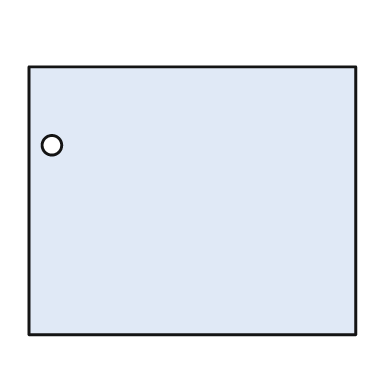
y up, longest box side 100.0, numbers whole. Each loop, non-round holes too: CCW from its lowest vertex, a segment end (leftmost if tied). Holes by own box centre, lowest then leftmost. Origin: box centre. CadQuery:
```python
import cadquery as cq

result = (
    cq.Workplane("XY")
    .moveTo(-50.0, -41.0)
    .lineTo(50.0, -41.0)
    .lineTo(50.0, 41.0)
    .lineTo(-50.0, 41.0)
    .close()
    .moveTo(-43.0, 17.0)
    .circle(3.0)
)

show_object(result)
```